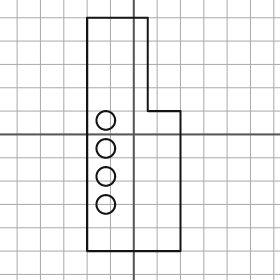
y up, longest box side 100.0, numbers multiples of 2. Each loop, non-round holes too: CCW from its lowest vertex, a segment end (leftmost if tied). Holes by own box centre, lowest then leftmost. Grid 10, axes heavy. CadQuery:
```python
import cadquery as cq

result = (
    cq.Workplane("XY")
    .moveTo(-20.0, -50.0)
    .lineTo(20.0, -50.0)
    .lineTo(20.0, 10.0)
    .lineTo(6.0, 10.0)
    .lineTo(6.0, 50.0)
    .lineTo(-20.0, 50.0)
    .close()
    .moveTo(-12.0, -30.0)
    .circle(4.0)
    .moveTo(-12.0, -18.0)
    .circle(4.0)
    .moveTo(-12.0, -6.0)
    .circle(4.0)
    .moveTo(-12.0, 6.0)
    .circle(4.0)
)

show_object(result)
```